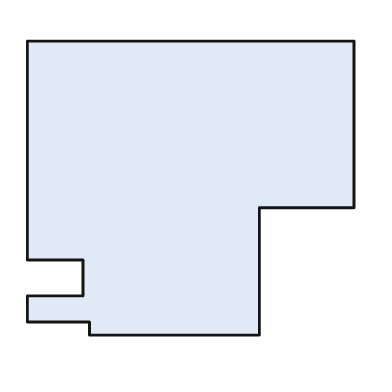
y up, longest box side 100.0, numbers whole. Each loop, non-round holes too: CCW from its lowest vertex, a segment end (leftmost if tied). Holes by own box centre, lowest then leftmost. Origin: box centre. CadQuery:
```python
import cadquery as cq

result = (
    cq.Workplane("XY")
    .moveTo(-31.0, -45.0)
    .lineTo(21.0, -45.0)
    .lineTo(21.0, -6.0)
    .lineTo(50.0, -6.0)
    .lineTo(50.0, 45.0)
    .lineTo(-50.0, 45.0)
    .lineTo(-50.0, -22.0)
    .lineTo(-33.0, -22.0)
    .lineTo(-33.0, -33.0)
    .lineTo(-50.0, -33.0)
    .lineTo(-50.0, -41.0)
    .lineTo(-31.0, -41.0)
    .close()
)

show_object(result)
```